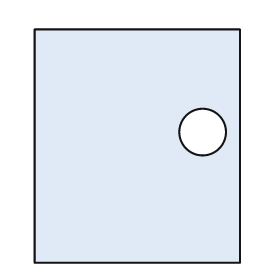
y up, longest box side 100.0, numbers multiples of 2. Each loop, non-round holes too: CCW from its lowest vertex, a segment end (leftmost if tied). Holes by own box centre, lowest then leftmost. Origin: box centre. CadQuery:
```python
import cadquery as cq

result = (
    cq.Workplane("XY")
    .moveTo(-44.0, -50.0)
    .lineTo(44.0, -50.0)
    .lineTo(44.0, 50.0)
    .lineTo(-44.0, 50.0)
    .close()
    .moveTo(28.0, 6.0)
    .circle(10.0)
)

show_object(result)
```